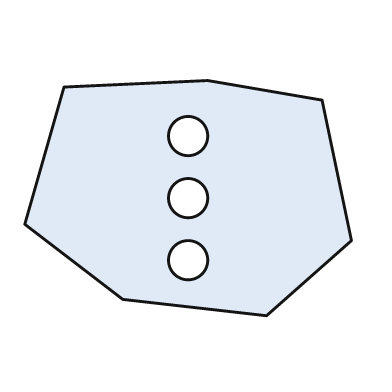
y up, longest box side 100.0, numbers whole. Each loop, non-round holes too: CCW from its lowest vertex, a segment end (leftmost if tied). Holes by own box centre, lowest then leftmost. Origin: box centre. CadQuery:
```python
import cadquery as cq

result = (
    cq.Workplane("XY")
    .moveTo(24.0, -36.0)
    .lineTo(50.0, -13.0)
    .lineTo(41.0, 30.0)
    .lineTo(6.0, 36.0)
    .lineTo(-38.0, 34.0)
    .lineTo(-50.0, -8.0)
    .lineTo(-20.0, -31.0)
    .close()
    .moveTo(0.0, -19.0)
    .circle(6.0)
    .moveTo(0.0, 0.0)
    .circle(6.0)
    .moveTo(0.0, 19.0)
    .circle(6.0)
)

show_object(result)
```